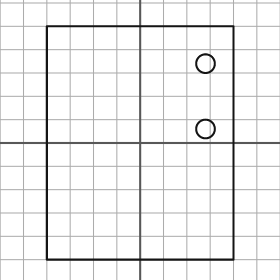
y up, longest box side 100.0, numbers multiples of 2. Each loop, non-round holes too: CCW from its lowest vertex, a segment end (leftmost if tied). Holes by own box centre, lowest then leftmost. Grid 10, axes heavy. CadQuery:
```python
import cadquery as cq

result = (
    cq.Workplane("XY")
    .moveTo(-40.0, -50.0)
    .lineTo(40.0, -50.0)
    .lineTo(40.0, 50.0)
    .lineTo(-40.0, 50.0)
    .close()
    .moveTo(28.0, 6.0)
    .circle(4.0)
    .moveTo(28.0, 34.0)
    .circle(4.0)
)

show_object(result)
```